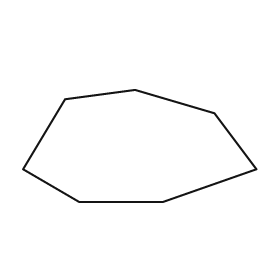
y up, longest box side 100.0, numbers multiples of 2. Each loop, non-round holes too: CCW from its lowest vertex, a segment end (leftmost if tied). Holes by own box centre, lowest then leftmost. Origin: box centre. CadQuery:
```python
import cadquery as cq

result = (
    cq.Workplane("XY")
    .moveTo(-26.0, -24.0)
    .lineTo(10.0, -24.0)
    .lineTo(50.0, -10.0)
    .lineTo(32.0, 14.0)
    .lineTo(-2.0, 24.0)
    .lineTo(-32.0, 20.0)
    .lineTo(-50.0, -10.0)
    .close()
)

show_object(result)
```